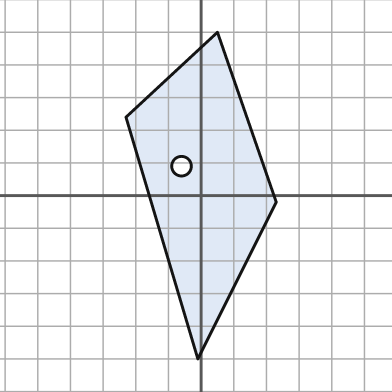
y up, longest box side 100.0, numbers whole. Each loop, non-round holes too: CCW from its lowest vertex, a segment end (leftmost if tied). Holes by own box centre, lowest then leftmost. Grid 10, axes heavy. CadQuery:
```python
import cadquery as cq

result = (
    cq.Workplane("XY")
    .moveTo(-1.0, -50.0)
    .lineTo(23.0, -2.0)
    .lineTo(5.0, 50.0)
    .lineTo(-23.0, 24.0)
    .close()
    .moveTo(-6.0, 9.0)
    .circle(3.0)
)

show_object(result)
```